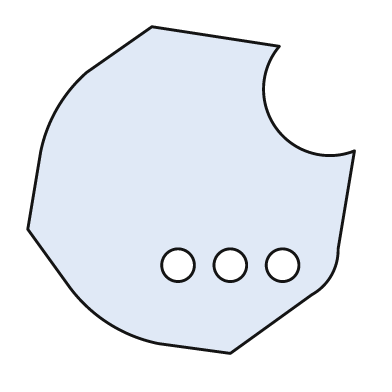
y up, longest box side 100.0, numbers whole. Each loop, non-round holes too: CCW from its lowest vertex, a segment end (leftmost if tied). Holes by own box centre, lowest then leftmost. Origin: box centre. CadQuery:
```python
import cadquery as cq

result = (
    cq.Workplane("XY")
    .moveTo(12.0, -50.0)
    .lineTo(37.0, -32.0)
    .threePointArc((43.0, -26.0), (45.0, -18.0))
    .lineTo(50.0, 12.0)
    .threePointArc((26.0, 19.0), (27.0, 44.0))
    .lineTo(-12.0, 50.0)
    .lineTo(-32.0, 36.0)
    .threePointArc((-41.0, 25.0), (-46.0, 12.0))
    .lineTo(-50.0, -12.0)
    .lineTo(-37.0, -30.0)
    .threePointArc((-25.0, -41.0), (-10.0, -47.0))
    .close()
    .moveTo(-4.0, -23.0)
    .circle(5.0)
    .moveTo(12.0, -23.0)
    .circle(5.0)
    .moveTo(28.0, -23.0)
    .circle(5.0)
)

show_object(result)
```